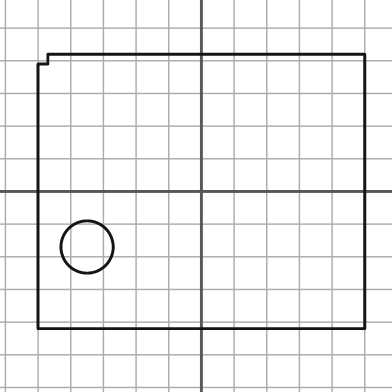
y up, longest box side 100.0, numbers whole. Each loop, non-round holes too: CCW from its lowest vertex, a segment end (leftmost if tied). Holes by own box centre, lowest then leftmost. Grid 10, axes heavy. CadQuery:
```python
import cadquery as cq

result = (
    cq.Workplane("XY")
    .moveTo(-50.0, -42.0)
    .lineTo(50.0, -42.0)
    .lineTo(50.0, 42.0)
    .lineTo(-47.0, 42.0)
    .lineTo(-47.0, 39.0)
    .lineTo(-50.0, 39.0)
    .close()
    .moveTo(-35.0, -17.0)
    .circle(8.0)
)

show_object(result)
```